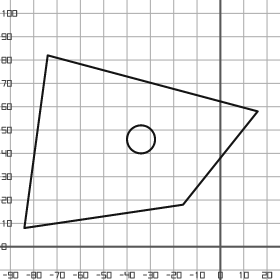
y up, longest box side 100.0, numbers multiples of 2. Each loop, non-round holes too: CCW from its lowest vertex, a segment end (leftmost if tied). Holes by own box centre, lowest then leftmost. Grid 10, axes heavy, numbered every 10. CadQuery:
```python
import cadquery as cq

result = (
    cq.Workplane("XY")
    .moveTo(-84.0, 8.0)
    .lineTo(-16.0, 18.0)
    .lineTo(16.0, 58.0)
    .lineTo(-74.0, 82.0)
    .close()
    .moveTo(-34.0, 46.0)
    .circle(6.0)
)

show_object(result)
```